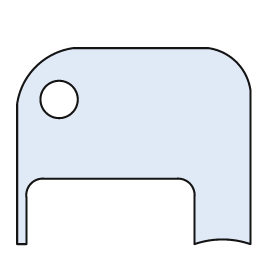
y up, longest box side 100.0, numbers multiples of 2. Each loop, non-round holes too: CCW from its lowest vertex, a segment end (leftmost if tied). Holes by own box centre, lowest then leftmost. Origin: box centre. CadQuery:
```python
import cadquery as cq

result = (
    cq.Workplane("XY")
    .moveTo(-50.0, -42.0)
    .lineTo(-46.0, -42.0)
    .lineTo(-46.0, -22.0)
    .threePointArc((-44.0, -16.0), (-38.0, -14.0))
    .lineTo(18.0, -14.0)
    .threePointArc((24.0, -16.0), (26.0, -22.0))
    .lineTo(26.0, -42.0)
    .threePointArc((38.0, -40.0), (50.0, -42.0))
    .lineTo(50.0, 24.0)
    .threePointArc((44.0, 36.0), (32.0, 42.0))
    .lineTo(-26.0, 42.0)
    .threePointArc((-42.0, 34.0), (-50.0, 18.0))
    .close()
    .moveTo(-32.0, 20.0)
    .circle(8.0)
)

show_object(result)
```